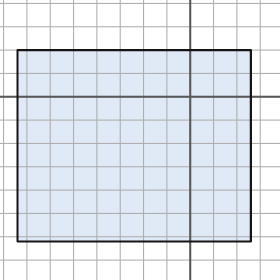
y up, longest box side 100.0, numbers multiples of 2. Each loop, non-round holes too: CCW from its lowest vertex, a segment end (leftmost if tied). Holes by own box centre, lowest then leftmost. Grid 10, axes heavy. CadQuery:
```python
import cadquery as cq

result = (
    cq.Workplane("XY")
    .moveTo(-74.0, -62.0)
    .lineTo(26.0, -62.0)
    .lineTo(26.0, 20.0)
    .lineTo(-74.0, 20.0)
    .close()
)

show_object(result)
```